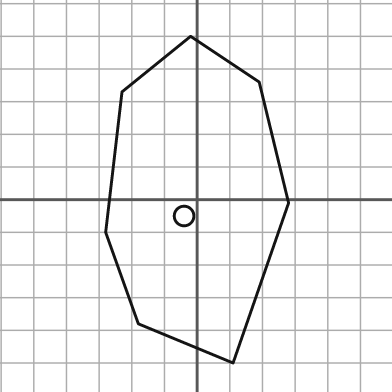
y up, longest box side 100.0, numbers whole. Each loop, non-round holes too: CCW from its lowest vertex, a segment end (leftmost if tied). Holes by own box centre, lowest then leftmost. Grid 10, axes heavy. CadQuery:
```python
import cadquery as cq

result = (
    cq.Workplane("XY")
    .moveTo(11.0, -50.0)
    .lineTo(28.0, -1.0)
    .lineTo(19.0, 36.0)
    .lineTo(-2.0, 50.0)
    .lineTo(-23.0, 33.0)
    .lineTo(-28.0, -10.0)
    .lineTo(-18.0, -38.0)
    .close()
    .moveTo(-4.0, -5.0)
    .circle(3.0)
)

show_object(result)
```